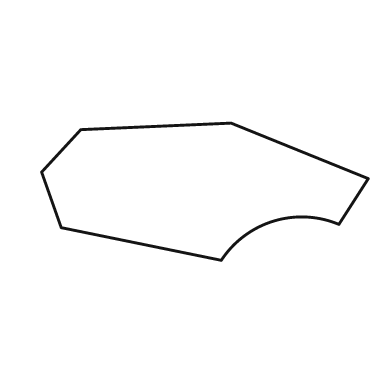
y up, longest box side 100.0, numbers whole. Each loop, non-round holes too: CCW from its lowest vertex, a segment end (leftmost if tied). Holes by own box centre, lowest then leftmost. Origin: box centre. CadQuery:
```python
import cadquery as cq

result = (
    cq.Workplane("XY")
    .moveTo(5.0, -21.0)
    .threePointArc((21.0, -9.0), (41.0, -10.0))
    .lineTo(50.0, 4.0)
    .lineTo(8.0, 21.0)
    .lineTo(-38.0, 19.0)
    .lineTo(-50.0, 6.0)
    .lineTo(-44.0, -11.0)
    .close()
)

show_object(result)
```